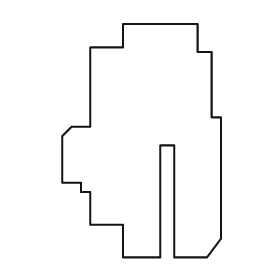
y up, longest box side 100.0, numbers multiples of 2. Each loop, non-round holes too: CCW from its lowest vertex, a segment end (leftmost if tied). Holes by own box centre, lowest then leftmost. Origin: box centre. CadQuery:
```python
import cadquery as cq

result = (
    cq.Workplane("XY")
    .moveTo(-8.0, -50.0)
    .lineTo(8.0, -50.0)
    .lineTo(8.0, -2.0)
    .lineTo(14.0, -2.0)
    .lineTo(14.0, -50.0)
    .lineTo(28.0, -50.0)
    .lineTo(34.0, -42.0)
    .lineTo(34.0, 10.0)
    .lineTo(30.0, 10.0)
    .lineTo(30.0, 38.0)
    .lineTo(24.0, 38.0)
    .lineTo(24.0, 50.0)
    .lineTo(-8.0, 50.0)
    .lineTo(-8.0, 40.0)
    .lineTo(-22.0, 40.0)
    .lineTo(-22.0, 6.0)
    .lineTo(-30.0, 6.0)
    .lineTo(-34.0, 2.0)
    .lineTo(-34.0, -18.0)
    .lineTo(-26.0, -18.0)
    .lineTo(-26.0, -22.0)
    .lineTo(-22.0, -22.0)
    .lineTo(-22.0, -36.0)
    .lineTo(-8.0, -36.0)
    .close()
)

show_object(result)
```